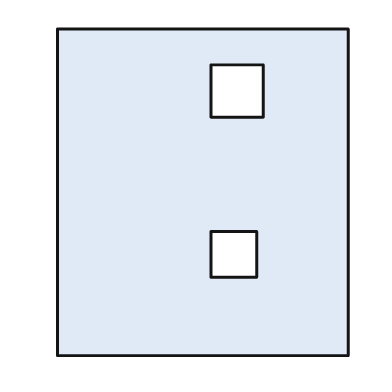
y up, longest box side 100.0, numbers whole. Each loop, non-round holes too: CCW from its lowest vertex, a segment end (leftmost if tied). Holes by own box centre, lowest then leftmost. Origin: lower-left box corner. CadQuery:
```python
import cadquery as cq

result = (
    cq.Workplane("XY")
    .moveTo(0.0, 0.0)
    .lineTo(89.0, 0.0)
    .lineTo(89.0, 100.0)
    .lineTo(0.0, 100.0)
    .close()
    .moveTo(47.0, 24.0)
    .lineTo(61.0, 24.0)
    .lineTo(61.0, 38.0)
    .lineTo(47.0, 38.0)
    .close()
    .moveTo(47.0, 73.0)
    .lineTo(63.0, 73.0)
    .lineTo(63.0, 89.0)
    .lineTo(47.0, 89.0)
    .close()
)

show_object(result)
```